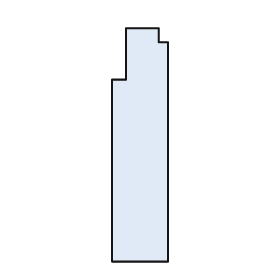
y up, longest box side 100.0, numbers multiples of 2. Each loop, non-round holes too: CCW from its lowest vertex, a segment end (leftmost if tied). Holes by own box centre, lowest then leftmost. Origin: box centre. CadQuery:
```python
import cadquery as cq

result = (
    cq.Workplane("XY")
    .moveTo(-12.0, -50.0)
    .lineTo(12.0, -50.0)
    .lineTo(12.0, 44.0)
    .lineTo(8.0, 44.0)
    .lineTo(8.0, 50.0)
    .lineTo(-6.0, 50.0)
    .lineTo(-6.0, 28.0)
    .lineTo(-12.0, 28.0)
    .close()
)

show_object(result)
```